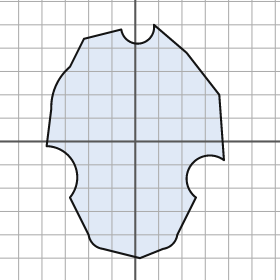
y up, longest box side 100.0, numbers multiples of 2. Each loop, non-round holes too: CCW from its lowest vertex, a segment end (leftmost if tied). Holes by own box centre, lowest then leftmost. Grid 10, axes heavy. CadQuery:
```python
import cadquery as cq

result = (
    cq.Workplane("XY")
    .moveTo(2.0, -50.0)
    .lineTo(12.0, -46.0)
    .threePointArc((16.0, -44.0), (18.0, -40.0))
    .lineTo(26.0, -24.0)
    .threePointArc((24.0, -10.0), (38.0, -8.0))
    .lineTo(36.0, 20.0)
    .lineTo(22.0, 38.0)
    .lineTo(8.0, 50.0)
    .threePointArc((2.0, 42.0), (-6.0, 48.0))
    .lineTo(-22.0, 44.0)
    .lineTo(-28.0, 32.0)
    .threePointArc((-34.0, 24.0), (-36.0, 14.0))
    .lineTo(-38.0, -2.0)
    .threePointArc((-26.0, -10.0), (-28.0, -24.0))
    .lineTo(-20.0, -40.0)
    .threePointArc((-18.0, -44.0), (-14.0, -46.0))
    .close()
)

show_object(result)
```